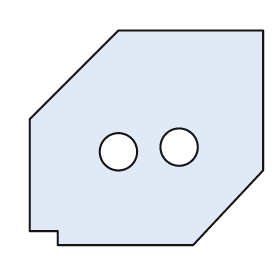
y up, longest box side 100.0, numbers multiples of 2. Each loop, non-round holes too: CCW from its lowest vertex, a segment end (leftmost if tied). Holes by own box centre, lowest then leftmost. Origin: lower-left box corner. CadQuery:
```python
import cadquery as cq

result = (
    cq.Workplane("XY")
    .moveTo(12.0, 0.0)
    .lineTo(70.0, 0.0)
    .lineTo(100.0, 32.0)
    .lineTo(100.0, 92.0)
    .lineTo(38.0, 92.0)
    .lineTo(0.0, 54.0)
    .lineTo(0.0, 6.0)
    .lineTo(12.0, 6.0)
    .close()
    .moveTo(38.0, 40.0)
    .circle(8.0)
    .moveTo(64.0, 42.0)
    .circle(8.0)
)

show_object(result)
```